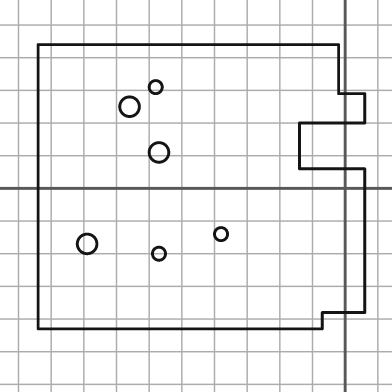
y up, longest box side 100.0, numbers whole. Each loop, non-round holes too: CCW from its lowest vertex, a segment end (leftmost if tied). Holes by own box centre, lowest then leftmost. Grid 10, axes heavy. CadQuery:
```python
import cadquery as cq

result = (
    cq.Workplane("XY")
    .moveTo(-94.0, -43.0)
    .lineTo(-7.0, -43.0)
    .lineTo(-7.0, -38.0)
    .lineTo(6.0, -38.0)
    .lineTo(6.0, 6.0)
    .lineTo(-14.0, 6.0)
    .lineTo(-14.0, 20.0)
    .lineTo(6.0, 20.0)
    .lineTo(6.0, 29.0)
    .lineTo(-2.0, 29.0)
    .lineTo(-2.0, 44.0)
    .lineTo(-94.0, 44.0)
    .close()
    .moveTo(-57.0, -20.0)
    .circle(2.0)
    .moveTo(-79.0, -17.0)
    .circle(3.0)
    .moveTo(-38.0, -14.0)
    .circle(2.0)
    .moveTo(-57.0, 11.0)
    .circle(3.0)
    .moveTo(-66.0, 25.0)
    .circle(3.0)
    .moveTo(-58.0, 31.0)
    .circle(2.0)
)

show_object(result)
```